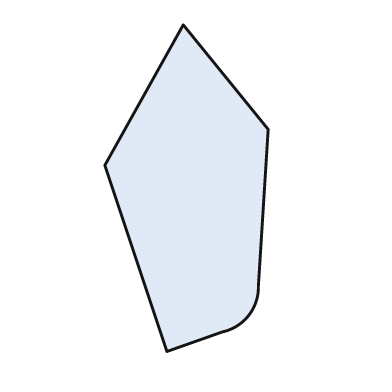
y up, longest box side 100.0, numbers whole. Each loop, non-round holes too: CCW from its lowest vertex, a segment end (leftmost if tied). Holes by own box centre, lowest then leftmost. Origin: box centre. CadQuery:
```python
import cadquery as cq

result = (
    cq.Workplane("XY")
    .moveTo(-6.0, -50.0)
    .lineTo(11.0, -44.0)
    .threePointArc((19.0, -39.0), (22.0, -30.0))
    .lineTo(25.0, 18.0)
    .lineTo(-1.0, 50.0)
    .lineTo(-25.0, 7.0)
    .close()
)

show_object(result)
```